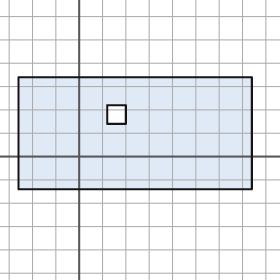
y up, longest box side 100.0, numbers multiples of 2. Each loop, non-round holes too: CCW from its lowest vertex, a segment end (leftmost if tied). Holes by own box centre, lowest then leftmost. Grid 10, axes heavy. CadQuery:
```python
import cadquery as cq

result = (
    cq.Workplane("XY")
    .moveTo(-26.0, -14.0)
    .lineTo(74.0, -14.0)
    .lineTo(74.0, 34.0)
    .lineTo(-26.0, 34.0)
    .close()
    .moveTo(12.0, 14.0)
    .lineTo(20.0, 14.0)
    .lineTo(20.0, 22.0)
    .lineTo(12.0, 22.0)
    .close()
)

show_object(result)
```